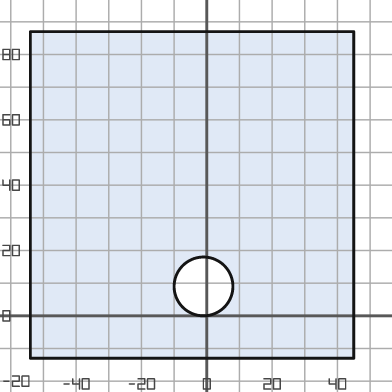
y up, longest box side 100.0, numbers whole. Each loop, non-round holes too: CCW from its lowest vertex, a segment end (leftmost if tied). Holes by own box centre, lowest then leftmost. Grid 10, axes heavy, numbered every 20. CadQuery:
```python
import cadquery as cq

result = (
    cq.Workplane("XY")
    .moveTo(-54.0, -13.0)
    .lineTo(45.0, -13.0)
    .lineTo(45.0, 87.0)
    .lineTo(-54.0, 87.0)
    .close()
    .moveTo(-1.0, 9.0)
    .circle(9.0)
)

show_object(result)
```